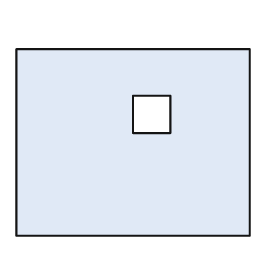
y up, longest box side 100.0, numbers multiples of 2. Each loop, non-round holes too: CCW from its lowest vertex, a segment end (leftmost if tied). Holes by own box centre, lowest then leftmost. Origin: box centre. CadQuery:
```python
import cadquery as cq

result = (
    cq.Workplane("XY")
    .moveTo(-50.0, -40.0)
    .lineTo(50.0, -40.0)
    .lineTo(50.0, 40.0)
    .lineTo(-50.0, 40.0)
    .close()
    .moveTo(0.0, 4.0)
    .lineTo(16.0, 4.0)
    .lineTo(16.0, 20.0)
    .lineTo(0.0, 20.0)
    .close()
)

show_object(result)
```